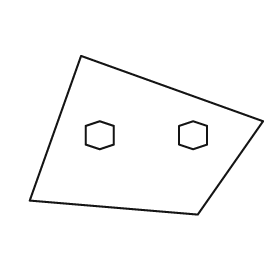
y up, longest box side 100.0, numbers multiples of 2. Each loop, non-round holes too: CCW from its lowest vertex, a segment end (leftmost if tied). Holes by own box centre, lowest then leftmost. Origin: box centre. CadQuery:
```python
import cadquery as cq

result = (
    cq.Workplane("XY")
    .moveTo(22.0, -34.0)
    .lineTo(50.0, 6.0)
    .lineTo(-28.0, 34.0)
    .lineTo(-50.0, -28.0)
    .close()
    .moveTo(-20.0, -6.0)
    .lineTo(-14.0, -4.0)
    .lineTo(-14.0, 4.0)
    .lineTo(-20.0, 6.0)
    .lineTo(-26.0, 4.0)
    .lineTo(-26.0, -4.0)
    .close()
    .moveTo(20.0, -6.0)
    .lineTo(26.0, -4.0)
    .lineTo(26.0, 4.0)
    .lineTo(20.0, 6.0)
    .lineTo(14.0, 4.0)
    .lineTo(14.0, -4.0)
    .close()
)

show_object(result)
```